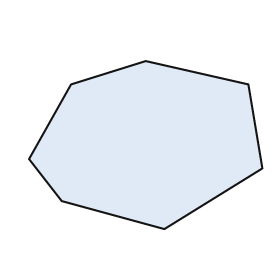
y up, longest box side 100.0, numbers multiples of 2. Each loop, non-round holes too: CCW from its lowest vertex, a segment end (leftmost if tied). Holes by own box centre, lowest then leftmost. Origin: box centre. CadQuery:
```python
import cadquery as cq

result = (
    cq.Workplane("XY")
    .moveTo(8.0, -36.0)
    .lineTo(50.0, -10.0)
    .lineTo(44.0, 26.0)
    .lineTo(0.0, 36.0)
    .lineTo(-32.0, 26.0)
    .lineTo(-50.0, -6.0)
    .lineTo(-36.0, -24.0)
    .close()
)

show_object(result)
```